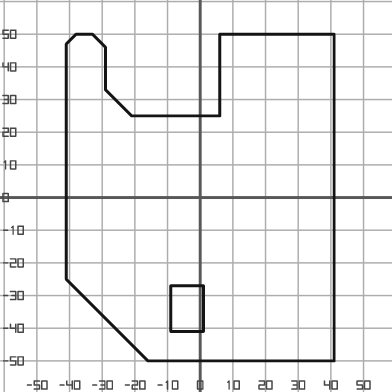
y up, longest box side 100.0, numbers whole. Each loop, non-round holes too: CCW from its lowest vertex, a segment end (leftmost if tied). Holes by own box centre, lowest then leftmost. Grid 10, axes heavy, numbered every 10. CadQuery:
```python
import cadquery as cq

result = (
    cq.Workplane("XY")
    .moveTo(-16.0, -50.0)
    .lineTo(41.0, -50.0)
    .lineTo(41.0, 50.0)
    .lineTo(6.0, 50.0)
    .lineTo(6.0, 25.0)
    .lineTo(-21.0, 25.0)
    .lineTo(-29.0, 33.0)
    .lineTo(-29.0, 46.0)
    .lineTo(-33.0, 50.0)
    .lineTo(-38.0, 50.0)
    .lineTo(-41.0, 47.0)
    .lineTo(-41.0, -25.0)
    .close()
    .moveTo(-9.0, -41.0)
    .lineTo(1.0, -41.0)
    .lineTo(1.0, -27.0)
    .lineTo(-9.0, -27.0)
    .close()
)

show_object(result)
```